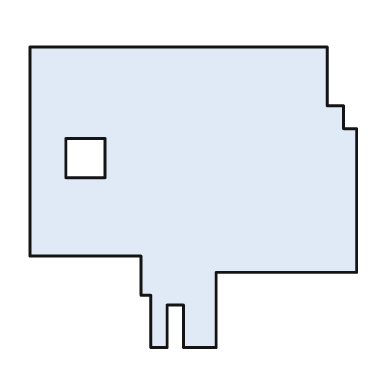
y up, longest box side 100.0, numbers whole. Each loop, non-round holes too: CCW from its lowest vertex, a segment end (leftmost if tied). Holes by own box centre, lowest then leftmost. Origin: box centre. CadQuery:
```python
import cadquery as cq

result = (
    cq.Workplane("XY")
    .moveTo(-13.0, -46.0)
    .lineTo(-8.0, -46.0)
    .lineTo(-8.0, -33.0)
    .lineTo(-3.0, -33.0)
    .lineTo(-3.0, -46.0)
    .lineTo(7.0, -46.0)
    .lineTo(7.0, -23.0)
    .lineTo(50.0, -23.0)
    .lineTo(50.0, 21.0)
    .lineTo(46.0, 21.0)
    .lineTo(46.0, 28.0)
    .lineTo(41.0, 28.0)
    .lineTo(41.0, 46.0)
    .lineTo(-50.0, 46.0)
    .lineTo(-50.0, -18.0)
    .lineTo(-16.0, -18.0)
    .lineTo(-16.0, -30.0)
    .lineTo(-13.0, -30.0)
    .close()
    .moveTo(-39.0, 6.0)
    .lineTo(-27.0, 6.0)
    .lineTo(-27.0, 18.0)
    .lineTo(-39.0, 18.0)
    .close()
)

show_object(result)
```